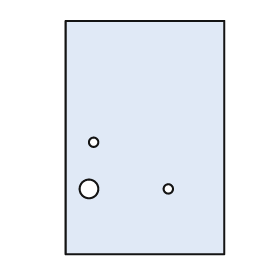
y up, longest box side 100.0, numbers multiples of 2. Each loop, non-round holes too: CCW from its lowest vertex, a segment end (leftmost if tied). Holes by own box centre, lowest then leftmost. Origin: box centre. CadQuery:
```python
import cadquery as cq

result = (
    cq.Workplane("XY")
    .moveTo(-34.0, -50.0)
    .lineTo(34.0, -50.0)
    .lineTo(34.0, 50.0)
    .lineTo(-34.0, 50.0)
    .close()
    .moveTo(-24.0, -22.0)
    .circle(4.0)
    .moveTo(10.0, -22.0)
    .circle(2.0)
    .moveTo(-22.0, -2.0)
    .circle(2.0)
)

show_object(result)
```